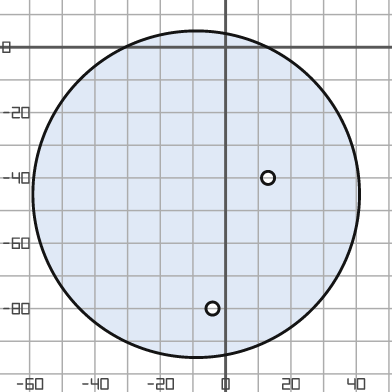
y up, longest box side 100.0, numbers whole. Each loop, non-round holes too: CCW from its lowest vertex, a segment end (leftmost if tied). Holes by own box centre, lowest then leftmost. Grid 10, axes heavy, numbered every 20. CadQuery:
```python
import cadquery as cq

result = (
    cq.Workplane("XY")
    .moveTo(-9.0, -45.0)
    .circle(50.0)
    .moveTo(-4.0, -80.0)
    .circle(2.0)
    .moveTo(13.0, -40.0)
    .circle(2.0)
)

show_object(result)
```